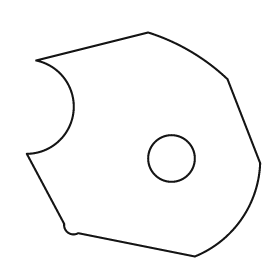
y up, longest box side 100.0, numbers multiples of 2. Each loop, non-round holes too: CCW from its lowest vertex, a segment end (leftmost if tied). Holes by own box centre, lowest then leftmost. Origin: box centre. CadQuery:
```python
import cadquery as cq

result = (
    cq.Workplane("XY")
    .moveTo(22.0, -48.0)
    .threePointArc((42.0, -32.0), (50.0, -8.0))
    .lineTo(36.0, 28.0)
    .threePointArc((20.0, 40.0), (2.0, 48.0))
    .lineTo(-46.0, 36.0)
    .threePointArc((-30.0, 14.0), (-50.0, -4.0))
    .lineTo(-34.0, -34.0)
    .threePointArc((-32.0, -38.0), (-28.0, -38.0))
    .close()
    .moveTo(12.0, -6.0)
    .circle(10.0)
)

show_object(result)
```